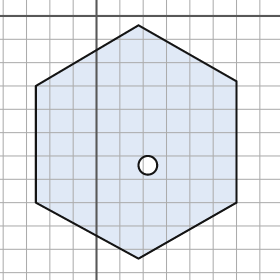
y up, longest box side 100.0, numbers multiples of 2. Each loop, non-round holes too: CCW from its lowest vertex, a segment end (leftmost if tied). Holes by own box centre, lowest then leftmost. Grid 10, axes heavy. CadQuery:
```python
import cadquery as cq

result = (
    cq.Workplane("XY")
    .moveTo(18.0, -104.0)
    .lineTo(60.0, -80.0)
    .lineTo(60.0, -28.0)
    .lineTo(18.0, -4.0)
    .lineTo(-26.0, -30.0)
    .lineTo(-26.0, -80.0)
    .close()
    .moveTo(22.0, -64.0)
    .circle(4.0)
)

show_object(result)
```